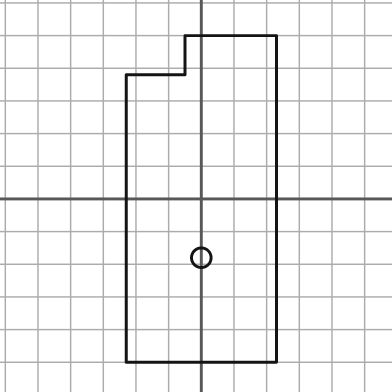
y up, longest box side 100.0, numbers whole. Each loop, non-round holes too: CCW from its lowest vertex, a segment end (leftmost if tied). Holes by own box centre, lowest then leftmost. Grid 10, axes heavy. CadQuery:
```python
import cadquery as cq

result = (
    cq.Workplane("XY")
    .moveTo(-23.0, -50.0)
    .lineTo(23.0, -50.0)
    .lineTo(23.0, 50.0)
    .lineTo(-5.0, 50.0)
    .lineTo(-5.0, 38.0)
    .lineTo(-23.0, 38.0)
    .close()
    .moveTo(0.0, -18.0)
    .circle(3.0)
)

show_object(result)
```